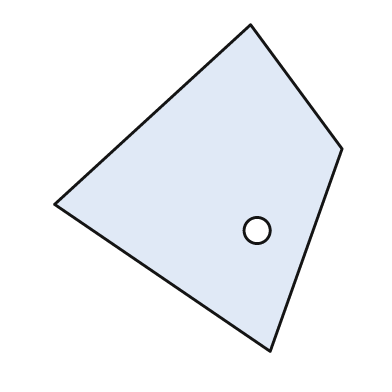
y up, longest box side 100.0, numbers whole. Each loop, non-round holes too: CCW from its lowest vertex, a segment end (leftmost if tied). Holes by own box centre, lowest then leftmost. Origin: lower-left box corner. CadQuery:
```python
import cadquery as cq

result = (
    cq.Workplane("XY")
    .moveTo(66.0, 0.0)
    .lineTo(88.0, 62.0)
    .lineTo(60.0, 100.0)
    .lineTo(0.0, 45.0)
    .close()
    .moveTo(62.0, 37.0)
    .circle(4.0)
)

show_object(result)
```